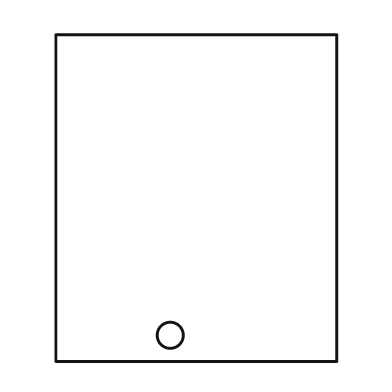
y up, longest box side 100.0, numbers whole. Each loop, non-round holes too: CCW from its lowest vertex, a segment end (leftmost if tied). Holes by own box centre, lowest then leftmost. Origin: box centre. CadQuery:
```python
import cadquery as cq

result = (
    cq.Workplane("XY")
    .moveTo(-43.0, -50.0)
    .lineTo(43.0, -50.0)
    .lineTo(43.0, 50.0)
    .lineTo(-43.0, 50.0)
    .close()
    .moveTo(-8.0, -42.0)
    .circle(4.0)
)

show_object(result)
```